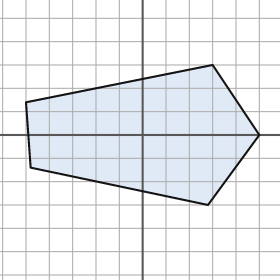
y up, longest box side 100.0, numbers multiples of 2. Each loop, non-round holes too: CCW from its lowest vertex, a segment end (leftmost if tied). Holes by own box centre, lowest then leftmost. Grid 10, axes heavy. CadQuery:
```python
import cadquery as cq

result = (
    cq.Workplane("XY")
    .moveTo(28.0, -30.0)
    .lineTo(50.0, 0.0)
    .lineTo(30.0, 30.0)
    .lineTo(-50.0, 14.0)
    .lineTo(-48.0, -14.0)
    .close()
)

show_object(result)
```